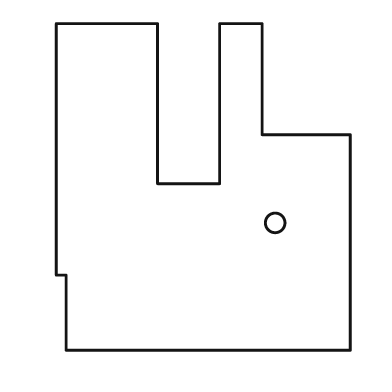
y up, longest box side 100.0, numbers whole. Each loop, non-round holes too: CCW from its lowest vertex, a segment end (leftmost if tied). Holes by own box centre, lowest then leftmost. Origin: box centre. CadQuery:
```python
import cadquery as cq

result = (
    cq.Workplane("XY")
    .moveTo(-42.0, -50.0)
    .lineTo(45.0, -50.0)
    .lineTo(45.0, 16.0)
    .lineTo(18.0, 16.0)
    .lineTo(18.0, 50.0)
    .lineTo(5.0, 50.0)
    .lineTo(5.0, 1.0)
    .lineTo(-14.0, 1.0)
    .lineTo(-14.0, 50.0)
    .lineTo(-45.0, 50.0)
    .lineTo(-45.0, -27.0)
    .lineTo(-42.0, -27.0)
    .close()
    .moveTo(22.0, -11.0)
    .circle(3.0)
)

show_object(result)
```